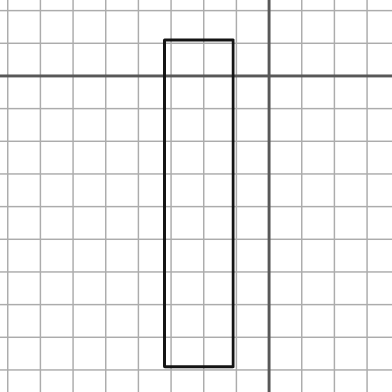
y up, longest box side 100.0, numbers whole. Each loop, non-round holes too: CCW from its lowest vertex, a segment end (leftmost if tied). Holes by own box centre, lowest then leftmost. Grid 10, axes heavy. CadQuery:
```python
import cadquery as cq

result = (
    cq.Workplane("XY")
    .moveTo(-32.0, -89.0)
    .lineTo(-11.0, -89.0)
    .lineTo(-11.0, 11.0)
    .lineTo(-32.0, 11.0)
    .close()
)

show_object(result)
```